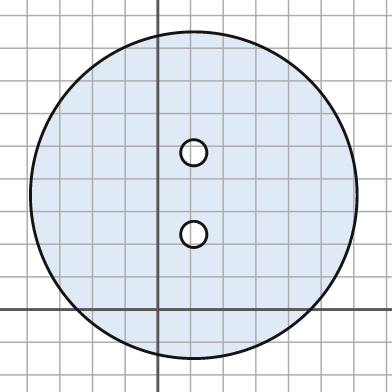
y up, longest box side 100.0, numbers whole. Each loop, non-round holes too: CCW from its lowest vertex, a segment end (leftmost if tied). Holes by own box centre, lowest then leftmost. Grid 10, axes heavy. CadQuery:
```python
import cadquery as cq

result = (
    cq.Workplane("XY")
    .moveTo(11.0, 35.0)
    .circle(50.0)
    .moveTo(11.0, 23.0)
    .circle(4.0)
    .moveTo(11.0, 48.0)
    .circle(4.0)
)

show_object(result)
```